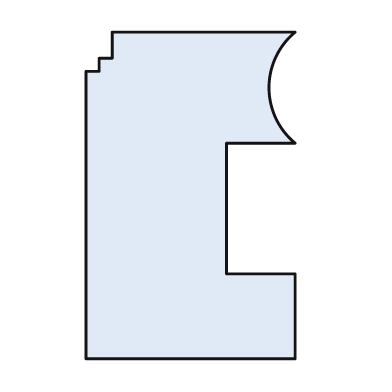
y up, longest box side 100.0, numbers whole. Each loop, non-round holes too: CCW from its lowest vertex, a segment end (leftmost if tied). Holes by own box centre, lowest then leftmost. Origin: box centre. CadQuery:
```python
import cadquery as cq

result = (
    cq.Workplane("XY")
    .moveTo(-32.0, -50.0)
    .lineTo(32.0, -50.0)
    .lineTo(32.0, -24.0)
    .lineTo(11.0, -24.0)
    .lineTo(11.0, 16.0)
    .lineTo(32.0, 16.0)
    .threePointArc((24.0, 33.0), (32.0, 50.0))
    .lineTo(-24.0, 50.0)
    .lineTo(-24.0, 42.0)
    .lineTo(-28.0, 42.0)
    .lineTo(-28.0, 38.0)
    .lineTo(-32.0, 38.0)
    .close()
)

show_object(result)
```